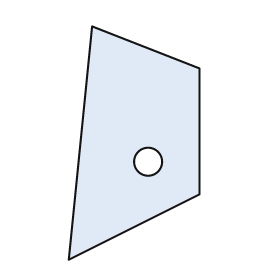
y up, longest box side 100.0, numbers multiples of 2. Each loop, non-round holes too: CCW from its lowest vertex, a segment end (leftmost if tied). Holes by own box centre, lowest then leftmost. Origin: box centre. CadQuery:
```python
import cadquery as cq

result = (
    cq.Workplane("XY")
    .moveTo(-28.0, -50.0)
    .lineTo(28.0, -22.0)
    .lineTo(28.0, 32.0)
    .lineTo(-18.0, 50.0)
    .close()
    .moveTo(6.0, -8.0)
    .circle(6.0)
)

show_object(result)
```